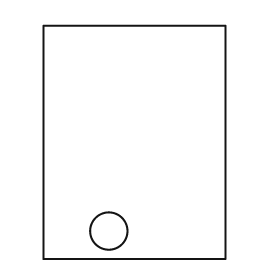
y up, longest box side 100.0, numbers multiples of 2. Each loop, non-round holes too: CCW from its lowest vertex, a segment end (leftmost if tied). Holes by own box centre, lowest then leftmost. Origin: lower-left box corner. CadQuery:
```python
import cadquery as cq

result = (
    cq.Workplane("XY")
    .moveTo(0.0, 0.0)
    .lineTo(78.0, 0.0)
    .lineTo(78.0, 100.0)
    .lineTo(0.0, 100.0)
    .close()
    .moveTo(28.0, 12.0)
    .circle(8.0)
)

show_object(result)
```